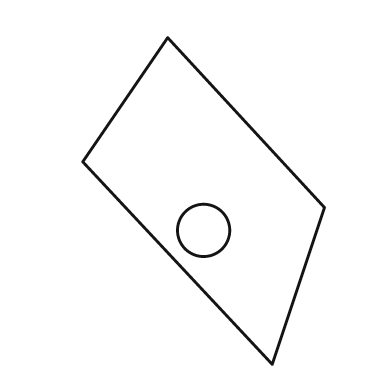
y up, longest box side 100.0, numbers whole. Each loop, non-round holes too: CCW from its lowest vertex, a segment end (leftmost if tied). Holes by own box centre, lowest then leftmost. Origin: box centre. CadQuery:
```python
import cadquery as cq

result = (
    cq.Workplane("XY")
    .moveTo(21.0, -50.0)
    .lineTo(37.0, -2.0)
    .lineTo(-11.0, 50.0)
    .lineTo(-37.0, 12.0)
    .close()
    .moveTo(0.0, -9.0)
    .circle(8.0)
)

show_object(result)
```